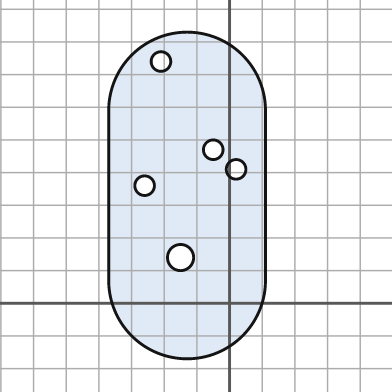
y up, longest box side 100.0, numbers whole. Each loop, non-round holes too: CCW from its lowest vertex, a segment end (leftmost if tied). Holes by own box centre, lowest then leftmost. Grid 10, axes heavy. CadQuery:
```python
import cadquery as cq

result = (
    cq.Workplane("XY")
    .moveTo(-37.0, 7.0)
    .threePointArc((-13.0, -17.0), (11.0, 7.0))
    .lineTo(11.0, 59.0)
    .threePointArc((-13.0, 83.0), (-37.0, 59.0))
    .close()
    .moveTo(-15.0, 14.0)
    .circle(4.0)
    .moveTo(-26.0, 36.0)
    .circle(3.0)
    .moveTo(2.0, 41.0)
    .circle(3.0)
    .moveTo(-5.0, 47.0)
    .circle(3.0)
    .moveTo(-21.0, 74.0)
    .circle(3.0)
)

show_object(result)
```